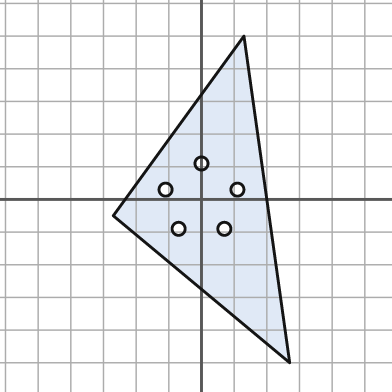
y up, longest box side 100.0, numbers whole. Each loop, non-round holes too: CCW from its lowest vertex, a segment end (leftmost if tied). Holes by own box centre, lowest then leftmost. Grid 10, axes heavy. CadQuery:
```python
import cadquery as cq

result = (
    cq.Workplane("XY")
    .moveTo(27.0, -50.0)
    .lineTo(13.0, 50.0)
    .lineTo(-27.0, -5.0)
    .close()
    .moveTo(-7.0, -9.0)
    .circle(2.0)
    .moveTo(7.0, -9.0)
    .circle(2.0)
    .moveTo(-11.0, 3.0)
    .circle(2.0)
    .moveTo(11.0, 3.0)
    .circle(2.0)
    .moveTo(0.0, 11.0)
    .circle(2.0)
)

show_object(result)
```